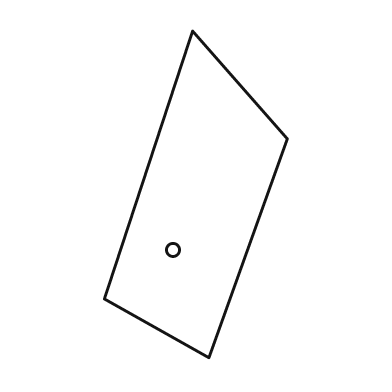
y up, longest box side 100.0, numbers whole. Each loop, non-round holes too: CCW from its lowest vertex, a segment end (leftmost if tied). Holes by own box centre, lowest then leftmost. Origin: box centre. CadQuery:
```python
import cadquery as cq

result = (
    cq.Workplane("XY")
    .moveTo(4.0, -50.0)
    .lineTo(28.0, 17.0)
    .lineTo(-1.0, 50.0)
    .lineTo(-28.0, -32.0)
    .close()
    .moveTo(-7.0, -17.0)
    .circle(2.0)
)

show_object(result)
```